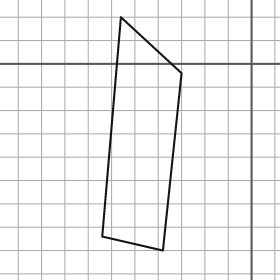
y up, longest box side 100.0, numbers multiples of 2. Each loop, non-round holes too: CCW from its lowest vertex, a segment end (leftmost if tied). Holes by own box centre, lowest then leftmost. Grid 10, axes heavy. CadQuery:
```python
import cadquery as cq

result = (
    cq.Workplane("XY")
    .moveTo(-38.0, -80.0)
    .lineTo(-30.0, -4.0)
    .lineTo(-56.0, 20.0)
    .lineTo(-64.0, -74.0)
    .close()
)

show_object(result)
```